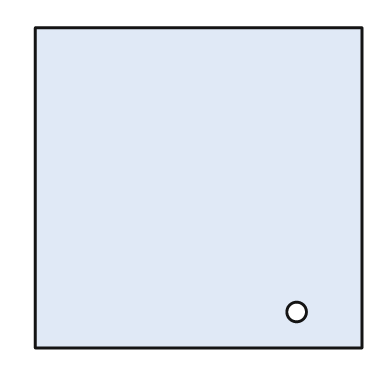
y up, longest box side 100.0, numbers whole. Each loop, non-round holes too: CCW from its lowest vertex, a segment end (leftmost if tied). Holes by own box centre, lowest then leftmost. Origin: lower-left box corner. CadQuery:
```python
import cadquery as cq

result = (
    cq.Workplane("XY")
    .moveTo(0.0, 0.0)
    .lineTo(100.0, 0.0)
    .lineTo(100.0, 98.0)
    .lineTo(0.0, 98.0)
    .close()
    .moveTo(80.0, 11.0)
    .circle(3.0)
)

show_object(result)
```